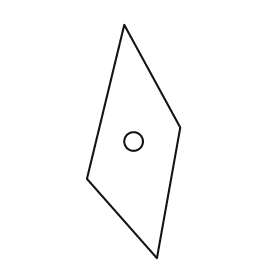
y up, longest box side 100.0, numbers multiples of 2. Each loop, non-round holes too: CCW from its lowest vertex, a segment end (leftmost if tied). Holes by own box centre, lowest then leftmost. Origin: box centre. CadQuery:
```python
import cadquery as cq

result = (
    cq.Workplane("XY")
    .moveTo(10.0, -50.0)
    .lineTo(20.0, 6.0)
    .lineTo(-4.0, 50.0)
    .lineTo(-20.0, -16.0)
    .close()
    .moveTo(0.0, 0.0)
    .circle(4.0)
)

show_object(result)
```